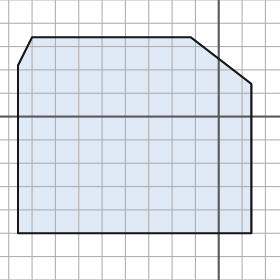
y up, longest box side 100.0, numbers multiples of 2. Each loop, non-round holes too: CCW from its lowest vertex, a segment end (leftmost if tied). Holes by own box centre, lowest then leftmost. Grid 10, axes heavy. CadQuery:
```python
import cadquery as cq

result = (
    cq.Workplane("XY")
    .moveTo(-86.0, -50.0)
    .lineTo(14.0, -50.0)
    .lineTo(14.0, 14.0)
    .lineTo(-12.0, 34.0)
    .lineTo(-80.0, 34.0)
    .lineTo(-86.0, 22.0)
    .close()
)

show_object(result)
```